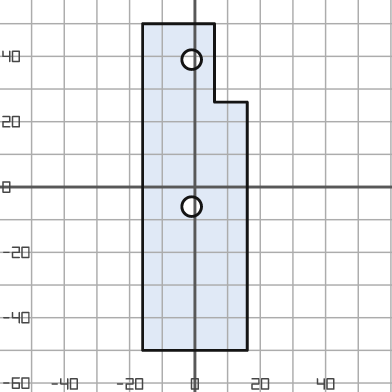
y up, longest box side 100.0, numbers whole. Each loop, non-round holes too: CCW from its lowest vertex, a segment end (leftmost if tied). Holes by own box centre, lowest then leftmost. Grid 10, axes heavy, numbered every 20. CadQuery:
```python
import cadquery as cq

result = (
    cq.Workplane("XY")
    .moveTo(-16.0, -50.0)
    .lineTo(16.0, -50.0)
    .lineTo(16.0, 26.0)
    .lineTo(6.0, 26.0)
    .lineTo(6.0, 50.0)
    .lineTo(-16.0, 50.0)
    .close()
    .moveTo(-1.0, -6.0)
    .circle(3.0)
    .moveTo(-1.0, 39.0)
    .circle(3.0)
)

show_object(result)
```